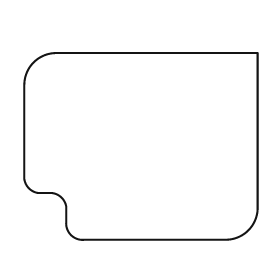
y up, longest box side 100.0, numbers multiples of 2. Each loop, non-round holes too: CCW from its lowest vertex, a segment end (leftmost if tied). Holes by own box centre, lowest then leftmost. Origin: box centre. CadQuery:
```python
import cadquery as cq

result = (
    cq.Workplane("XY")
    .moveTo(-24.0, -40.0)
    .lineTo(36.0, -40.0)
    .threePointArc((46.0, -36.0), (50.0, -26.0))
    .lineTo(50.0, 40.0)
    .lineTo(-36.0, 40.0)
    .threePointArc((-46.0, 36.0), (-50.0, 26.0))
    .lineTo(-50.0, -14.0)
    .threePointArc((-48.0, -18.0), (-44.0, -20.0))
    .lineTo(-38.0, -20.0)
    .threePointArc((-34.0, -22.0), (-32.0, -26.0))
    .lineTo(-32.0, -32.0)
    .threePointArc((-30.0, -38.0), (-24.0, -40.0))
    .close()
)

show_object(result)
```